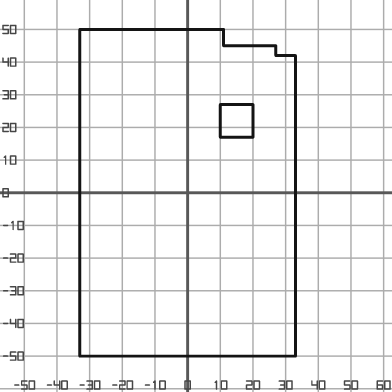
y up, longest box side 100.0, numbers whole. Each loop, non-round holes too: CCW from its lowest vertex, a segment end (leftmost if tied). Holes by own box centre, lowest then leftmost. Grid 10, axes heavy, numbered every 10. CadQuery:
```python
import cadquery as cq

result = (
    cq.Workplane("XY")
    .moveTo(-33.0, -50.0)
    .lineTo(33.0, -50.0)
    .lineTo(33.0, 42.0)
    .lineTo(27.0, 42.0)
    .lineTo(27.0, 45.0)
    .lineTo(11.0, 45.0)
    .lineTo(11.0, 50.0)
    .lineTo(-33.0, 50.0)
    .close()
    .moveTo(10.0, 17.0)
    .lineTo(20.0, 17.0)
    .lineTo(20.0, 27.0)
    .lineTo(10.0, 27.0)
    .close()
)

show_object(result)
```